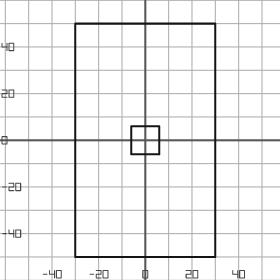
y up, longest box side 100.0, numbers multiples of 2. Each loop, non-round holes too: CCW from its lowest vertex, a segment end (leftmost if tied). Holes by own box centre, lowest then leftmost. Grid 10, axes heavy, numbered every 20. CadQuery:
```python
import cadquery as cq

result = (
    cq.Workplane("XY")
    .moveTo(-30.0, -50.0)
    .lineTo(30.0, -50.0)
    .lineTo(30.0, 50.0)
    .lineTo(-30.0, 50.0)
    .close()
    .moveTo(-6.0, -6.0)
    .lineTo(6.0, -6.0)
    .lineTo(6.0, 6.0)
    .lineTo(-6.0, 6.0)
    .close()
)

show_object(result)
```